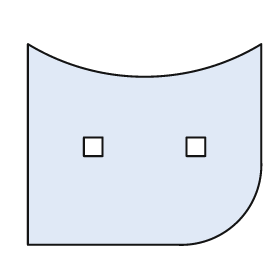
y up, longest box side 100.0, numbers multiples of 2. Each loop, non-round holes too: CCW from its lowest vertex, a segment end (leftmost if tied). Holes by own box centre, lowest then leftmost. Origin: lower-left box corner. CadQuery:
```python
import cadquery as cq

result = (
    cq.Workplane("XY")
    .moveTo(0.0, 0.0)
    .lineTo(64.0, 0.0)
    .threePointArc((90.0, 10.0), (100.0, 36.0))
    .lineTo(100.0, 86.0)
    .threePointArc((50.0, 72.0), (0.0, 86.0))
    .close()
    .moveTo(24.0, 38.0)
    .lineTo(32.0, 38.0)
    .lineTo(32.0, 46.0)
    .lineTo(24.0, 46.0)
    .close()
    .moveTo(68.0, 38.0)
    .lineTo(76.0, 38.0)
    .lineTo(76.0, 46.0)
    .lineTo(68.0, 46.0)
    .close()
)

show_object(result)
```